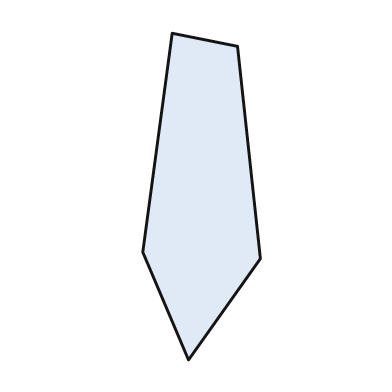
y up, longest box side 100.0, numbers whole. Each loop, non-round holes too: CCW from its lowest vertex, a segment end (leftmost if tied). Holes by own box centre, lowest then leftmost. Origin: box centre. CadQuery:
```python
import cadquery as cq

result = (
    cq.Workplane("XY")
    .moveTo(-4.0, -50.0)
    .lineTo(18.0, -19.0)
    .lineTo(11.0, 46.0)
    .lineTo(-9.0, 50.0)
    .lineTo(-18.0, -17.0)
    .close()
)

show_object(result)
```